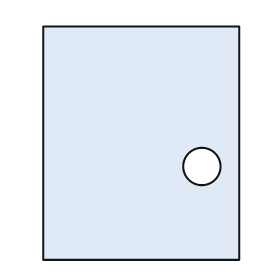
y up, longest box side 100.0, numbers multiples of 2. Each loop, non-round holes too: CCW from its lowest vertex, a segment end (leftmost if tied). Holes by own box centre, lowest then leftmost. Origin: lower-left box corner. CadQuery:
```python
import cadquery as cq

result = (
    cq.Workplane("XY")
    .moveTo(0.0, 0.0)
    .lineTo(84.0, 0.0)
    .lineTo(84.0, 100.0)
    .lineTo(0.0, 100.0)
    .close()
    .moveTo(68.0, 40.0)
    .circle(8.0)
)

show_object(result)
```